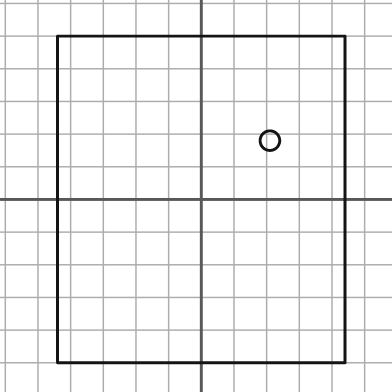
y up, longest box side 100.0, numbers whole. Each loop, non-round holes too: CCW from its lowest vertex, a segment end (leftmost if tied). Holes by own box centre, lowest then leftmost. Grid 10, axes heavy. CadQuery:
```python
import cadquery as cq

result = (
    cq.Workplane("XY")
    .moveTo(-44.0, -50.0)
    .lineTo(44.0, -50.0)
    .lineTo(44.0, 50.0)
    .lineTo(-44.0, 50.0)
    .close()
    .moveTo(21.0, 18.0)
    .circle(3.0)
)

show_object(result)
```